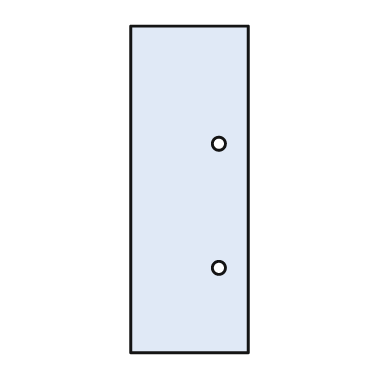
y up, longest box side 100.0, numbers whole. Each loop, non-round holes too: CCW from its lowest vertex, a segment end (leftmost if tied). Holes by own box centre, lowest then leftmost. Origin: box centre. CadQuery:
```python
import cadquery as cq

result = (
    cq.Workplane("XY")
    .moveTo(-18.0, -50.0)
    .lineTo(18.0, -50.0)
    .lineTo(18.0, 50.0)
    .lineTo(-18.0, 50.0)
    .close()
    .moveTo(9.0, -24.0)
    .circle(2.0)
    .moveTo(9.0, 14.0)
    .circle(2.0)
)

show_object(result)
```